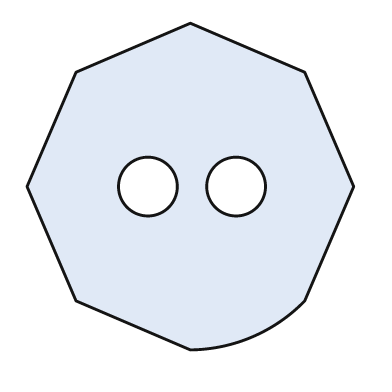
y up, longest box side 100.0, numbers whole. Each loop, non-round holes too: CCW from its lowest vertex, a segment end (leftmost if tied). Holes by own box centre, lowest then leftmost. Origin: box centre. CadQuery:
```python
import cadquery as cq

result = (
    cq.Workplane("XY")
    .moveTo(0.0, -50.0)
    .threePointArc((19.0, -46.0), (35.0, -35.0))
    .lineTo(50.0, 0.0)
    .lineTo(35.0, 35.0)
    .lineTo(0.0, 50.0)
    .lineTo(-35.0, 35.0)
    .lineTo(-50.0, 0.0)
    .lineTo(-35.0, -35.0)
    .close()
    .moveTo(-13.0, 0.0)
    .circle(9.0)
    .moveTo(14.0, 0.0)
    .circle(9.0)
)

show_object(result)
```